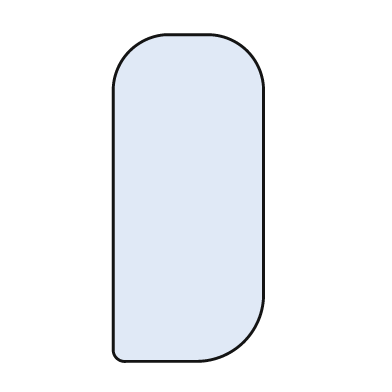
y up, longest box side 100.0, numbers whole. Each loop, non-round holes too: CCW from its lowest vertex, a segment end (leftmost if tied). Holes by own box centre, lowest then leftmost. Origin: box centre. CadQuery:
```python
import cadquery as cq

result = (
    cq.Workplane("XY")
    .moveTo(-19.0, -50.0)
    .lineTo(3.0, -50.0)
    .threePointArc((17.0, -44.0), (23.0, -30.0))
    .lineTo(23.0, 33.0)
    .threePointArc((18.0, 45.0), (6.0, 50.0))
    .lineTo(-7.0, 50.0)
    .threePointArc((-18.0, 45.0), (-23.0, 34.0))
    .lineTo(-23.0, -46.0)
    .threePointArc((-22.0, -49.0), (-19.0, -50.0))
    .close()
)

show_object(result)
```